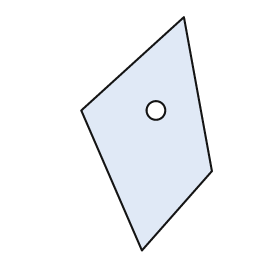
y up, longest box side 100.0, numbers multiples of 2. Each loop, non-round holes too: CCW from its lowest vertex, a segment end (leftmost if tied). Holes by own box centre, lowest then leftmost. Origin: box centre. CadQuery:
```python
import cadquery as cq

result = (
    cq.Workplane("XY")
    .moveTo(-2.0, -50.0)
    .lineTo(28.0, -16.0)
    .lineTo(16.0, 50.0)
    .lineTo(-28.0, 10.0)
    .close()
    .moveTo(4.0, 10.0)
    .circle(4.0)
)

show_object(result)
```